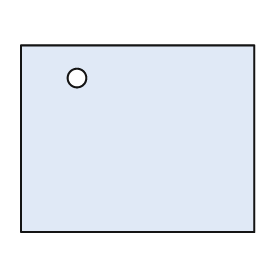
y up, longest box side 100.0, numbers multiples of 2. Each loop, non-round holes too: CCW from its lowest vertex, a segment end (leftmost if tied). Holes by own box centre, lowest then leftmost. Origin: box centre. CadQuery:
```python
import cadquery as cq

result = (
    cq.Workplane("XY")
    .moveTo(-50.0, -40.0)
    .lineTo(50.0, -40.0)
    .lineTo(50.0, 40.0)
    .lineTo(-50.0, 40.0)
    .close()
    .moveTo(-26.0, 26.0)
    .circle(4.0)
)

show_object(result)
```